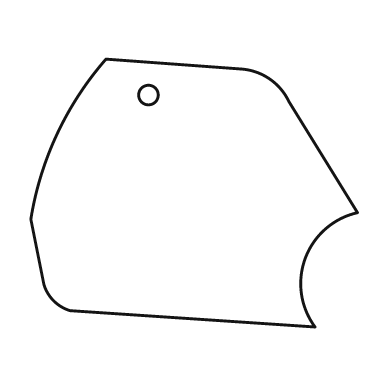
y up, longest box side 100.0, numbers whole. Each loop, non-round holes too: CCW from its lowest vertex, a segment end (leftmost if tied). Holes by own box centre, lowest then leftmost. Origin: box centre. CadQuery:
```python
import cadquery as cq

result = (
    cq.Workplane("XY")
    .moveTo(37.0, -41.0)
    .threePointArc((34.0, -20.0), (50.0, -6.0))
    .lineTo(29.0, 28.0)
    .threePointArc((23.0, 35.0), (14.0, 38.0))
    .lineTo(-27.0, 41.0)
    .threePointArc((-42.0, 18.0), (-50.0, -8.0))
    .lineTo(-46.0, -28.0)
    .threePointArc((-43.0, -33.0), (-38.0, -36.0))
    .close()
    .moveTo(-14.0, 30.0)
    .circle(3.0)
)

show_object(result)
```